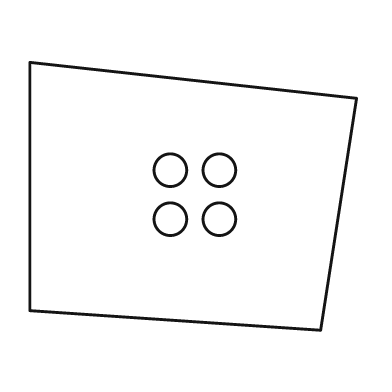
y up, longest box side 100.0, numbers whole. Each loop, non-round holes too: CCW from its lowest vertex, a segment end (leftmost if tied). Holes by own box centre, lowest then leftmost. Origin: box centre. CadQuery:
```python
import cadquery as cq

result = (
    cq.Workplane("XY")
    .moveTo(39.0, -41.0)
    .lineTo(50.0, 30.0)
    .lineTo(-50.0, 41.0)
    .lineTo(-50.0, -35.0)
    .close()
    .moveTo(-7.0, -7.0)
    .circle(5.0)
    .moveTo(8.0, -7.0)
    .circle(5.0)
    .moveTo(-7.0, 8.0)
    .circle(5.0)
    .moveTo(8.0, 8.0)
    .circle(5.0)
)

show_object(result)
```